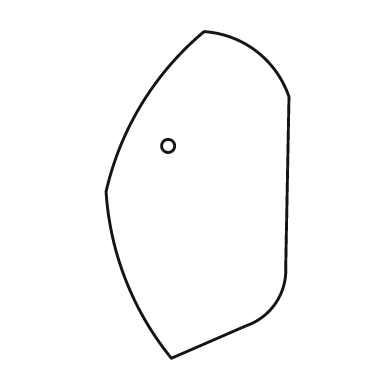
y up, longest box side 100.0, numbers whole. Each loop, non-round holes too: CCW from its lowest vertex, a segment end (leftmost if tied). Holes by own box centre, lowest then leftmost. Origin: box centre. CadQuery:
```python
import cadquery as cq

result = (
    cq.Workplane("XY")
    .moveTo(-8.0, -50.0)
    .lineTo(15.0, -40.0)
    .threePointArc((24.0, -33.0), (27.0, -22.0))
    .lineTo(28.0, 30.0)
    .threePointArc((18.0, 44.0), (2.0, 50.0))
    .threePointArc((-17.0, 28.0), (-28.0, 1.0))
    .threePointArc((-22.0, -26.0), (-8.0, -50.0))
    .close()
    .moveTo(-9.0, 15.0)
    .circle(2.0)
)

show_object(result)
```